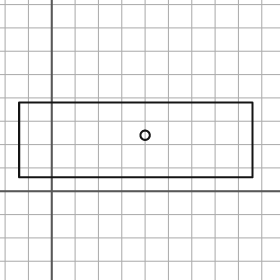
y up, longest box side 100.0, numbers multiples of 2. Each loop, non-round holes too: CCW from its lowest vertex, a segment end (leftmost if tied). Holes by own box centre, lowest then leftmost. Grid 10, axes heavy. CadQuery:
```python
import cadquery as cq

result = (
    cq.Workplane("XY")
    .moveTo(-14.0, 6.0)
    .lineTo(86.0, 6.0)
    .lineTo(86.0, 38.0)
    .lineTo(-14.0, 38.0)
    .close()
    .moveTo(40.0, 24.0)
    .circle(2.0)
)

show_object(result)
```